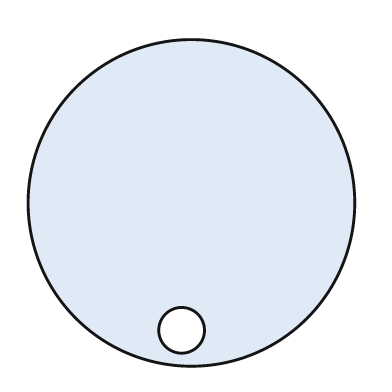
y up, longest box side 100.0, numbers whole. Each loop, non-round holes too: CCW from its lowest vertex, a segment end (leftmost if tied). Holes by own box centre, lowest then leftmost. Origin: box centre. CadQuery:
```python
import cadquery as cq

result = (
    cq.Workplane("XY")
    .moveTo(0.0, 0.0)
    .circle(50.0)
    .moveTo(-3.0, -39.0)
    .circle(7.0)
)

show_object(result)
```